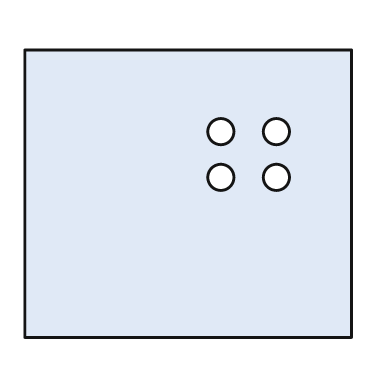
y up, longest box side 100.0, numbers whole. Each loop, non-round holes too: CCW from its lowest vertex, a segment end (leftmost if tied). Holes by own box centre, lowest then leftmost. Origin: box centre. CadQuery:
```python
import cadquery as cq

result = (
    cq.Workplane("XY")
    .moveTo(-50.0, -44.0)
    .lineTo(50.0, -44.0)
    .lineTo(50.0, 44.0)
    .lineTo(-50.0, 44.0)
    .close()
    .moveTo(10.0, 5.0)
    .circle(4.0)
    .moveTo(27.0, 5.0)
    .circle(4.0)
    .moveTo(10.0, 19.0)
    .circle(4.0)
    .moveTo(27.0, 19.0)
    .circle(4.0)
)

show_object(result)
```